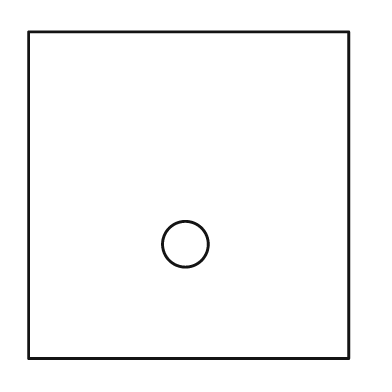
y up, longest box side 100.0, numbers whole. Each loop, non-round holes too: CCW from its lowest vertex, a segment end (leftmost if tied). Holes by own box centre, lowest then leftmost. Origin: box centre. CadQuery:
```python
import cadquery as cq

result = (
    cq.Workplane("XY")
    .moveTo(-49.0, -50.0)
    .lineTo(49.0, -50.0)
    .lineTo(49.0, 50.0)
    .lineTo(-49.0, 50.0)
    .close()
    .moveTo(-1.0, -15.0)
    .circle(7.0)
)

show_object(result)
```